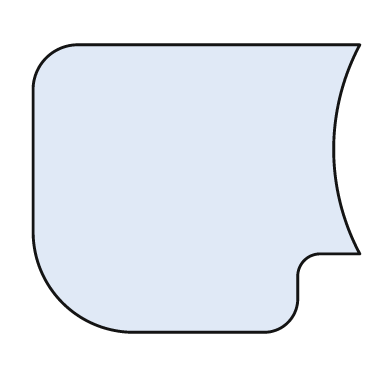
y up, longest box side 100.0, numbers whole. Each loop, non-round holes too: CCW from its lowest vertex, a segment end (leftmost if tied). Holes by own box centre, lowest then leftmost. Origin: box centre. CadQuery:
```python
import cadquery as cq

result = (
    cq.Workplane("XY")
    .moveTo(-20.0, -44.0)
    .lineTo(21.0, -44.0)
    .threePointArc((28.0, -41.0), (31.0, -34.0))
    .lineTo(31.0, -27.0)
    .threePointArc((33.0, -22.0), (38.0, -20.0))
    .lineTo(50.0, -20.0)
    .threePointArc((42.0, 12.0), (50.0, 44.0))
    .lineTo(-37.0, 44.0)
    .threePointArc((-46.0, 40.0), (-50.0, 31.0))
    .lineTo(-50.0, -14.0)
    .threePointArc((-41.0, -35.0), (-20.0, -44.0))
    .close()
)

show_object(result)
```